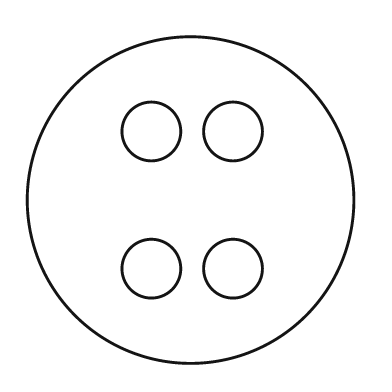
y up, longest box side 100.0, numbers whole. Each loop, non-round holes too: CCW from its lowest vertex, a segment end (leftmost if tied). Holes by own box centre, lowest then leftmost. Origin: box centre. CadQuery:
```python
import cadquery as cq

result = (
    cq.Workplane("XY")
    .moveTo(0.0, 0.0)
    .circle(50.0)
    .moveTo(-12.0, -21.0)
    .circle(9.0)
    .moveTo(13.0, -21.0)
    .circle(9.0)
    .moveTo(-12.0, 21.0)
    .circle(9.0)
    .moveTo(13.0, 21.0)
    .circle(9.0)
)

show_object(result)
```